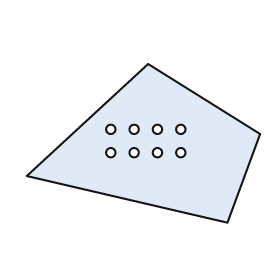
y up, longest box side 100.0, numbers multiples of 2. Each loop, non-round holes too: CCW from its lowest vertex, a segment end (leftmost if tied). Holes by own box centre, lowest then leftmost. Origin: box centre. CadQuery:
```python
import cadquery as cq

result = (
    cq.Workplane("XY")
    .moveTo(36.0, -34.0)
    .lineTo(50.0, 4.0)
    .lineTo(2.0, 34.0)
    .lineTo(-50.0, -14.0)
    .close()
    .moveTo(-14.0, -4.0)
    .circle(2.0)
    .moveTo(-4.0, -4.0)
    .circle(2.0)
    .moveTo(6.0, -4.0)
    .circle(2.0)
    .moveTo(16.0, -4.0)
    .circle(2.0)
    .moveTo(-14.0, 6.0)
    .circle(2.0)
    .moveTo(-4.0, 6.0)
    .circle(2.0)
    .moveTo(6.0, 6.0)
    .circle(2.0)
    .moveTo(16.0, 6.0)
    .circle(2.0)
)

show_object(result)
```